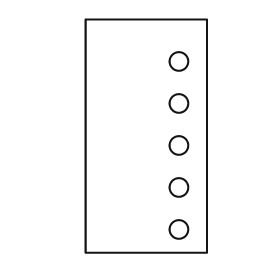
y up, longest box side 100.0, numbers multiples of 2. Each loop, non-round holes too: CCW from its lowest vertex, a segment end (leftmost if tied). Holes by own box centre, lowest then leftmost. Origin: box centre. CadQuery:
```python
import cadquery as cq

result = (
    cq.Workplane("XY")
    .moveTo(-26.0, -50.0)
    .lineTo(26.0, -50.0)
    .lineTo(26.0, 50.0)
    .lineTo(-26.0, 50.0)
    .close()
    .moveTo(14.0, -40.0)
    .circle(4.0)
    .moveTo(14.0, -22.0)
    .circle(4.0)
    .moveTo(14.0, -4.0)
    .circle(4.0)
    .moveTo(14.0, 14.0)
    .circle(4.0)
    .moveTo(14.0, 32.0)
    .circle(4.0)
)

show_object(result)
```